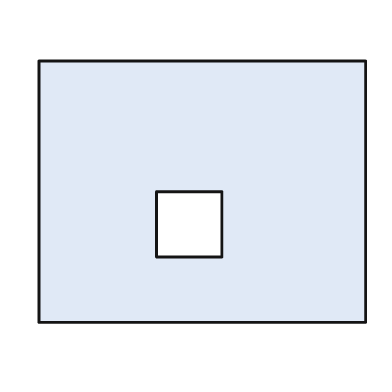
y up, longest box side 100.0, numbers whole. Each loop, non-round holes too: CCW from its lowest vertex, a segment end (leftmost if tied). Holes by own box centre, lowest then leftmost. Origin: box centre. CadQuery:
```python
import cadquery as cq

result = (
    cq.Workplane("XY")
    .moveTo(-50.0, -40.0)
    .lineTo(50.0, -40.0)
    .lineTo(50.0, 40.0)
    .lineTo(-50.0, 40.0)
    .close()
    .moveTo(-14.0, -20.0)
    .lineTo(6.0, -20.0)
    .lineTo(6.0, 0.0)
    .lineTo(-14.0, 0.0)
    .close()
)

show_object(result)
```